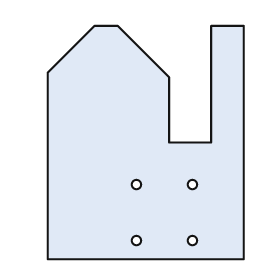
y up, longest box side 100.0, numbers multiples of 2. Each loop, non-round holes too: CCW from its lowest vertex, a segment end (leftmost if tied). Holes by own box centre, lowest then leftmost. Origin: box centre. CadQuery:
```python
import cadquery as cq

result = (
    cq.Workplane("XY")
    .moveTo(-42.0, -50.0)
    .lineTo(42.0, -50.0)
    .lineTo(42.0, 50.0)
    .lineTo(28.0, 50.0)
    .lineTo(28.0, 0.0)
    .lineTo(10.0, 0.0)
    .lineTo(10.0, 28.0)
    .lineTo(-12.0, 50.0)
    .lineTo(-22.0, 50.0)
    .lineTo(-42.0, 30.0)
    .close()
    .moveTo(-4.0, -42.0)
    .circle(2.0)
    .moveTo(20.0, -42.0)
    .circle(2.0)
    .moveTo(-4.0, -18.0)
    .circle(2.0)
    .moveTo(20.0, -18.0)
    .circle(2.0)
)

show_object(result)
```